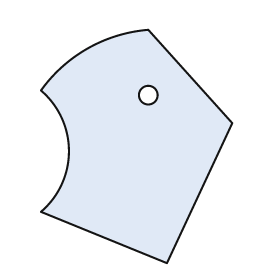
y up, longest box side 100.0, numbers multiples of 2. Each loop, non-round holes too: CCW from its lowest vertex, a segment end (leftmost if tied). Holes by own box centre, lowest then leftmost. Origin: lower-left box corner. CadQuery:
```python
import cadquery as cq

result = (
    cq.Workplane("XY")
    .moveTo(54.0, 0.0)
    .lineTo(82.0, 60.0)
    .lineTo(46.0, 100.0)
    .threePointArc((20.0, 92.0), (0.0, 74.0))
    .threePointArc((12.0, 48.0), (0.0, 22.0))
    .close()
    .moveTo(46.0, 72.0)
    .circle(4.0)
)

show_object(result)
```